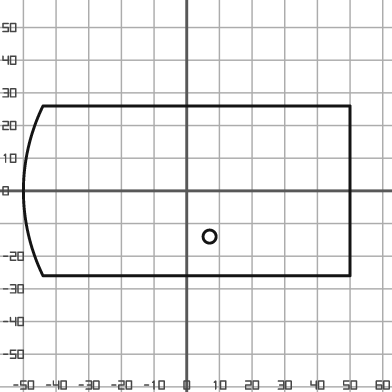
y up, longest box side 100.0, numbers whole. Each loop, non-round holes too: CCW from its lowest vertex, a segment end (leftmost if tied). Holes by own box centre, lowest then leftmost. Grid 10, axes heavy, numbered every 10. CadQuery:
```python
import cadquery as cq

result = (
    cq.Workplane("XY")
    .moveTo(-44.0, -26.0)
    .lineTo(50.0, -26.0)
    .lineTo(50.0, 26.0)
    .lineTo(-44.0, 26.0)
    .threePointArc((-50.0, 0.0), (-44.0, -26.0))
    .close()
    .moveTo(7.0, -14.0)
    .circle(2.0)
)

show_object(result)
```